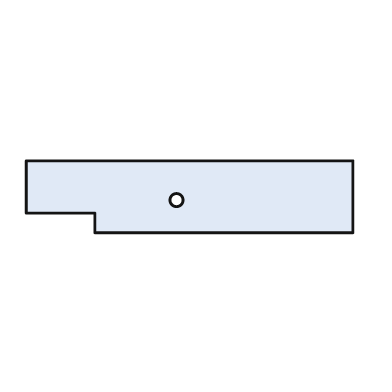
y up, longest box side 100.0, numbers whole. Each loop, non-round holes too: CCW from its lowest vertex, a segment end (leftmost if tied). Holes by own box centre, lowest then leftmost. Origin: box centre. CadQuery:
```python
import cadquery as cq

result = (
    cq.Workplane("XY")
    .moveTo(-29.0, -11.0)
    .lineTo(50.0, -11.0)
    .lineTo(50.0, 11.0)
    .lineTo(-50.0, 11.0)
    .lineTo(-50.0, -5.0)
    .lineTo(-29.0, -5.0)
    .close()
    .moveTo(-4.0, -1.0)
    .circle(2.0)
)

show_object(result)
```